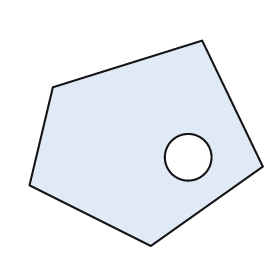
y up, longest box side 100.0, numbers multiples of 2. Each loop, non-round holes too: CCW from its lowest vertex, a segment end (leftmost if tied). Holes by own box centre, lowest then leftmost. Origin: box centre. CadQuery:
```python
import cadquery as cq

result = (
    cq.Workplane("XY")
    .moveTo(2.0, -44.0)
    .lineTo(50.0, -10.0)
    .lineTo(24.0, 44.0)
    .lineTo(-40.0, 24.0)
    .lineTo(-50.0, -18.0)
    .close()
    .moveTo(18.0, -6.0)
    .circle(10.0)
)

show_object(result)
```